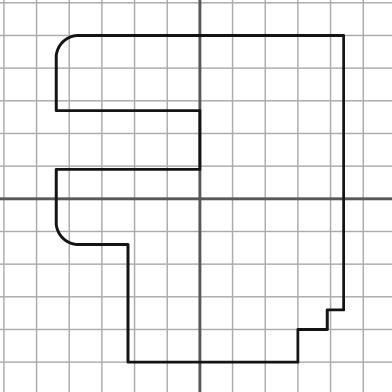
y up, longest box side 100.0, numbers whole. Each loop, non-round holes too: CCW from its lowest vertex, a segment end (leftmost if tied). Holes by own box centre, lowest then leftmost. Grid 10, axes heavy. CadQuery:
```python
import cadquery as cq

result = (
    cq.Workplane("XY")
    .moveTo(-22.0, -50.0)
    .lineTo(30.0, -50.0)
    .lineTo(30.0, -40.0)
    .lineTo(39.0, -40.0)
    .lineTo(39.0, -34.0)
    .lineTo(44.0, -34.0)
    .lineTo(44.0, 50.0)
    .lineTo(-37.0, 50.0)
    .threePointArc((-42.0, 48.0), (-44.0, 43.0))
    .lineTo(-44.0, 27.0)
    .lineTo(0.0, 27.0)
    .lineTo(0.0, 9.0)
    .lineTo(-44.0, 9.0)
    .lineTo(-44.0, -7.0)
    .threePointArc((-42.0, -12.0), (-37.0, -14.0))
    .lineTo(-22.0, -14.0)
    .close()
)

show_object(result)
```